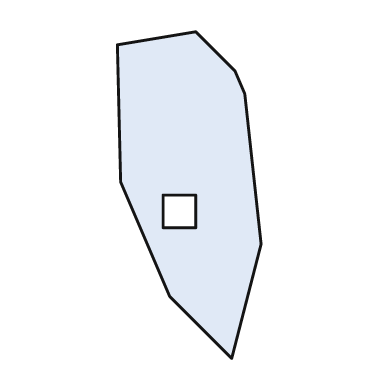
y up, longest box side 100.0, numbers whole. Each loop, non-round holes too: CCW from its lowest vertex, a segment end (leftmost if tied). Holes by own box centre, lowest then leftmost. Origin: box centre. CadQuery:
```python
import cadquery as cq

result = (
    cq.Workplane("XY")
    .moveTo(13.0, -50.0)
    .lineTo(22.0, -15.0)
    .lineTo(17.0, 31.0)
    .lineTo(14.0, 38.0)
    .lineTo(2.0, 50.0)
    .lineTo(-22.0, 46.0)
    .lineTo(-21.0, 4.0)
    .lineTo(-6.0, -31.0)
    .close()
    .moveTo(-8.0, -10.0)
    .lineTo(2.0, -10.0)
    .lineTo(2.0, 0.0)
    .lineTo(-8.0, 0.0)
    .close()
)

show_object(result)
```